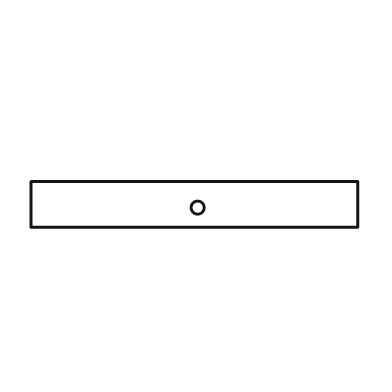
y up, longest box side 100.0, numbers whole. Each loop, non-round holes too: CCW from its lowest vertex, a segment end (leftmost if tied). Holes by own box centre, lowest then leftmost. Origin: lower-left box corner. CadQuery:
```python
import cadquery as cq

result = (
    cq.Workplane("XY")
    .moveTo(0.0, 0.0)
    .lineTo(100.0, 0.0)
    .lineTo(100.0, 14.0)
    .lineTo(0.0, 14.0)
    .close()
    .moveTo(51.0, 6.0)
    .circle(2.0)
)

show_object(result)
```